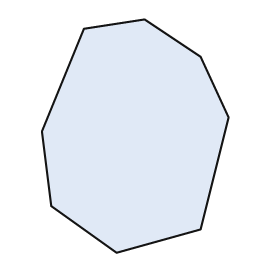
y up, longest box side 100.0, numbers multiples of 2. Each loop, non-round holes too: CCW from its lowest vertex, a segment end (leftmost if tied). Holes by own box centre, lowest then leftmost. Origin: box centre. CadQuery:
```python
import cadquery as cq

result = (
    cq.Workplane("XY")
    .moveTo(-8.0, -50.0)
    .lineTo(28.0, -40.0)
    .lineTo(40.0, 8.0)
    .lineTo(28.0, 34.0)
    .lineTo(4.0, 50.0)
    .lineTo(-22.0, 46.0)
    .lineTo(-40.0, 2.0)
    .lineTo(-36.0, -30.0)
    .close()
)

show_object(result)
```